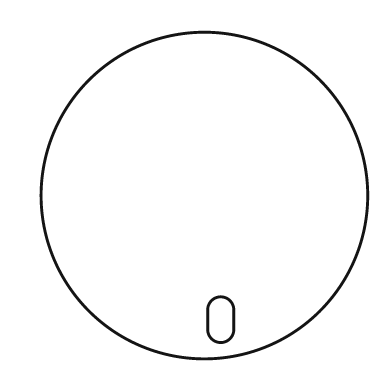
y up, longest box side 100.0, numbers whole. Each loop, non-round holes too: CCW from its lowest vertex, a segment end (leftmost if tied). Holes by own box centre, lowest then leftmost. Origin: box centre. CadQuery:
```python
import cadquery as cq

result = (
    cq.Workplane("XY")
    .moveTo(0.0, 0.0)
    .circle(50.0)
    .moveTo(1.0, -41.0)
    .threePointArc((5.0, -45.0), (9.0, -41.0))
    .lineTo(9.0, -35.0)
    .threePointArc((5.0, -31.0), (1.0, -35.0))
    .close()
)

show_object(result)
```